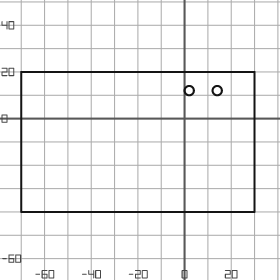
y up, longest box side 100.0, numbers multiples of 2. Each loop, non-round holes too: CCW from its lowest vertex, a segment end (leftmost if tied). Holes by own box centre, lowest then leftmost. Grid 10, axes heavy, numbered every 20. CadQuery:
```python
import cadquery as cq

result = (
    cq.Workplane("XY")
    .moveTo(-70.0, -40.0)
    .lineTo(30.0, -40.0)
    .lineTo(30.0, 20.0)
    .lineTo(-70.0, 20.0)
    .close()
    .moveTo(2.0, 12.0)
    .circle(2.0)
    .moveTo(14.0, 12.0)
    .circle(2.0)
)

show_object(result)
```